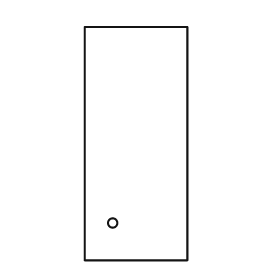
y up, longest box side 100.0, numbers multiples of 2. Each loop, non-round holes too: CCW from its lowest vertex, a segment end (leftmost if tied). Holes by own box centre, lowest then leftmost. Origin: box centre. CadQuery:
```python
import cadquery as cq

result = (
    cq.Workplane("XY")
    .moveTo(-22.0, -50.0)
    .lineTo(22.0, -50.0)
    .lineTo(22.0, 50.0)
    .lineTo(-22.0, 50.0)
    .close()
    .moveTo(-10.0, -34.0)
    .circle(2.0)
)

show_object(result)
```